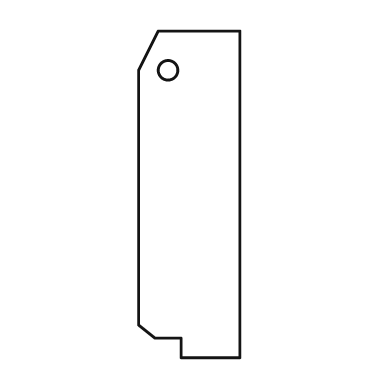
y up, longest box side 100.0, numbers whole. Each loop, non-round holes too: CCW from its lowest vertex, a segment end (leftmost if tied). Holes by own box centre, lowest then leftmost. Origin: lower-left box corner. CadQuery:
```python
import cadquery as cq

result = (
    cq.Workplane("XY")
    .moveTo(13.0, 0.0)
    .lineTo(31.0, 0.0)
    .lineTo(31.0, 100.0)
    .lineTo(6.0, 100.0)
    .lineTo(0.0, 88.0)
    .lineTo(0.0, 10.0)
    .lineTo(5.0, 6.0)
    .lineTo(13.0, 6.0)
    .close()
    .moveTo(9.0, 88.0)
    .circle(3.0)
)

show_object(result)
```